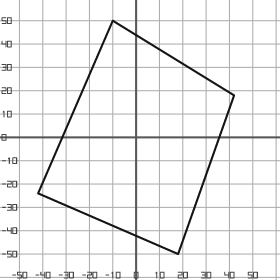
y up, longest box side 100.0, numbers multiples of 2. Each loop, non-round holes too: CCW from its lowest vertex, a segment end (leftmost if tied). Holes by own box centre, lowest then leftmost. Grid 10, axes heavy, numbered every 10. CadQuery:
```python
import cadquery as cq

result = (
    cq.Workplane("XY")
    .moveTo(18.0, -50.0)
    .lineTo(42.0, 18.0)
    .lineTo(-10.0, 50.0)
    .lineTo(-42.0, -24.0)
    .close()
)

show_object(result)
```